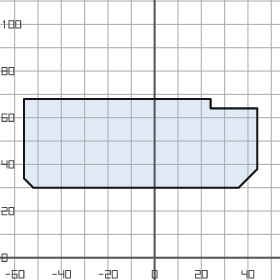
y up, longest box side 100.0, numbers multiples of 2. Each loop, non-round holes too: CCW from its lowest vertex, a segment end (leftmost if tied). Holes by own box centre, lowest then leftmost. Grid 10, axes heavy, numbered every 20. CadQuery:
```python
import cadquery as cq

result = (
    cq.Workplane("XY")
    .moveTo(-52.0, 30.0)
    .lineTo(36.0, 30.0)
    .lineTo(44.0, 38.0)
    .lineTo(44.0, 64.0)
    .lineTo(24.0, 64.0)
    .lineTo(24.0, 68.0)
    .lineTo(-56.0, 68.0)
    .lineTo(-56.0, 34.0)
    .close()
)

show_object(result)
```